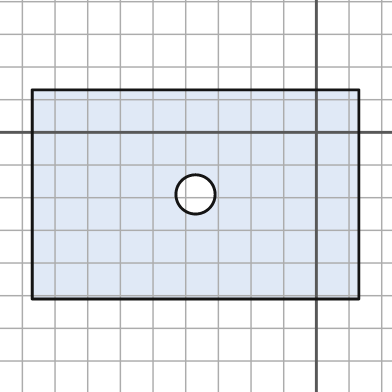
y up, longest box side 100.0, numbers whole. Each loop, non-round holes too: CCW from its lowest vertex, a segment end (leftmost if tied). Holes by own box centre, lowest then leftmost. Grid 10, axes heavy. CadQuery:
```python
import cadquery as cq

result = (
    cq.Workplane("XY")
    .moveTo(-87.0, -51.0)
    .lineTo(13.0, -51.0)
    .lineTo(13.0, 13.0)
    .lineTo(-87.0, 13.0)
    .close()
    .moveTo(-37.0, -19.0)
    .circle(6.0)
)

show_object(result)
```